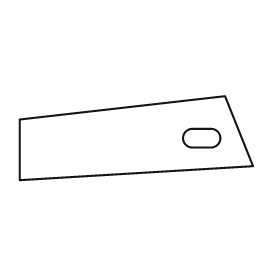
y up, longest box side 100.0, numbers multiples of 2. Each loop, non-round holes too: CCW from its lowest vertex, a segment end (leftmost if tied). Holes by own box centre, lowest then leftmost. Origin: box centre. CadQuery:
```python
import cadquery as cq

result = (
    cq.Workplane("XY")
    .moveTo(-50.0, -18.0)
    .lineTo(50.0, -12.0)
    .lineTo(38.0, 18.0)
    .lineTo(-50.0, 8.0)
    .close()
    .moveTo(24.0, -4.0)
    .lineTo(32.0, -4.0)
    .threePointArc((36.0, 0.0), (32.0, 4.0))
    .lineTo(24.0, 4.0)
    .threePointArc((20.0, 0.0), (24.0, -4.0))
    .close()
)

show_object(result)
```